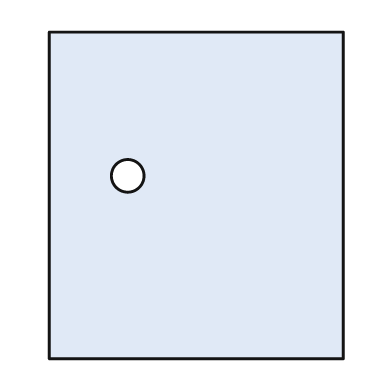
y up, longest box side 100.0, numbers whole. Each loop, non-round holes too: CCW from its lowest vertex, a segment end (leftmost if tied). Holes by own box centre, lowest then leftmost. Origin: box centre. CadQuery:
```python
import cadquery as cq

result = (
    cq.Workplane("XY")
    .moveTo(-45.0, -50.0)
    .lineTo(45.0, -50.0)
    .lineTo(45.0, 50.0)
    .lineTo(-45.0, 50.0)
    .close()
    .moveTo(-21.0, 6.0)
    .circle(5.0)
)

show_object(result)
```